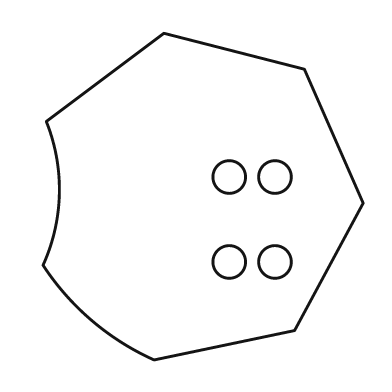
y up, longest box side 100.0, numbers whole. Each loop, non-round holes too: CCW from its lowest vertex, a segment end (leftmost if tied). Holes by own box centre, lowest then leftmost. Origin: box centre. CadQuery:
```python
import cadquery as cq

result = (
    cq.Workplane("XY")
    .moveTo(-15.0, -50.0)
    .lineTo(28.0, -41.0)
    .lineTo(49.0, -2.0)
    .lineTo(31.0, 39.0)
    .lineTo(-12.0, 50.0)
    .lineTo(-48.0, 23.0)
    .threePointArc((-44.0, 1.0), (-49.0, -21.0))
    .threePointArc((-34.0, -38.0), (-15.0, -50.0))
    .close()
    .moveTo(8.0, -20.0)
    .circle(5.0)
    .moveTo(22.0, -20.0)
    .circle(5.0)
    .moveTo(8.0, 6.0)
    .circle(5.0)
    .moveTo(22.0, 6.0)
    .circle(5.0)
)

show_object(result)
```